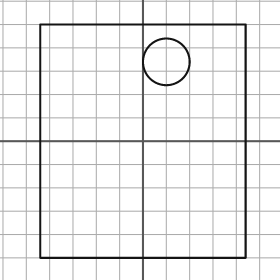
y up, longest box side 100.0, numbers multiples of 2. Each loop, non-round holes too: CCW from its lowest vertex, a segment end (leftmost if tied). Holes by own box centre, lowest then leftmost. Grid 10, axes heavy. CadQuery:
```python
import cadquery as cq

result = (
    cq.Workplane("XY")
    .moveTo(-44.0, -50.0)
    .lineTo(44.0, -50.0)
    .lineTo(44.0, 50.0)
    .lineTo(-44.0, 50.0)
    .close()
    .moveTo(10.0, 34.0)
    .circle(10.0)
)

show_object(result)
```